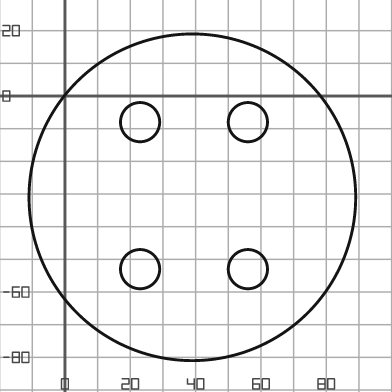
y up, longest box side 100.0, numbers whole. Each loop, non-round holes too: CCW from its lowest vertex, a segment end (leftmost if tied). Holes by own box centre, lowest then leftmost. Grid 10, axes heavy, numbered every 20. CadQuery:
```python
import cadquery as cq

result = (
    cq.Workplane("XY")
    .moveTo(39.0, -31.0)
    .circle(50.0)
    .moveTo(23.0, -53.0)
    .circle(6.0)
    .moveTo(56.0, -53.0)
    .circle(6.0)
    .moveTo(23.0, -8.0)
    .circle(6.0)
    .moveTo(56.0, -8.0)
    .circle(6.0)
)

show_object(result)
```